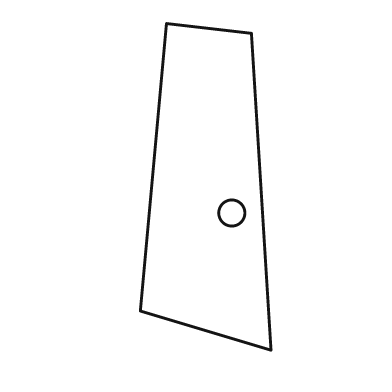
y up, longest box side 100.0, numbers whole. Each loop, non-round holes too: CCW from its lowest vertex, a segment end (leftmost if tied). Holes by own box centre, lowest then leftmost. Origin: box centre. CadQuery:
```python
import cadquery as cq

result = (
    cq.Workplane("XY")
    .moveTo(20.0, -50.0)
    .lineTo(14.0, 47.0)
    .lineTo(-12.0, 50.0)
    .lineTo(-20.0, -38.0)
    .close()
    .moveTo(8.0, -8.0)
    .circle(4.0)
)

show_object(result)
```